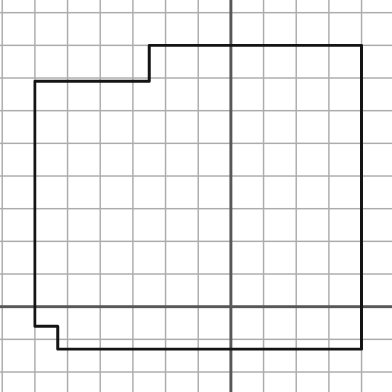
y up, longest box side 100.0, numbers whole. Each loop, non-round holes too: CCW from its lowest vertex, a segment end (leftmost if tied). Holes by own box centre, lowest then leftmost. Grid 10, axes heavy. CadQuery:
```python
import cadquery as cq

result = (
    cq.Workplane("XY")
    .moveTo(-53.0, -13.0)
    .lineTo(40.0, -13.0)
    .lineTo(40.0, 80.0)
    .lineTo(-25.0, 80.0)
    .lineTo(-25.0, 69.0)
    .lineTo(-60.0, 69.0)
    .lineTo(-60.0, -6.0)
    .lineTo(-53.0, -6.0)
    .close()
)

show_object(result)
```